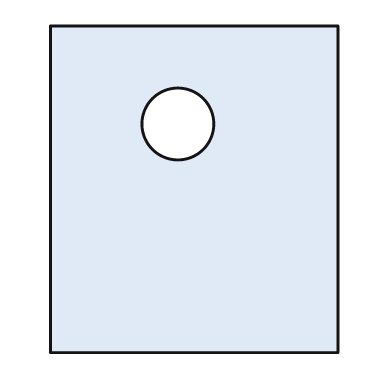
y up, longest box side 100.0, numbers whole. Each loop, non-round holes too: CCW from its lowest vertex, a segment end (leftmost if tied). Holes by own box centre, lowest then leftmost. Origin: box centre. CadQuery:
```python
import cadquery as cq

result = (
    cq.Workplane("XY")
    .moveTo(-44.0, -50.0)
    .lineTo(44.0, -50.0)
    .lineTo(44.0, 50.0)
    .lineTo(-44.0, 50.0)
    .close()
    .moveTo(-5.0, 20.0)
    .circle(11.0)
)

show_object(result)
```